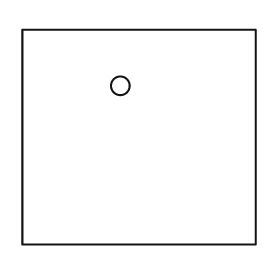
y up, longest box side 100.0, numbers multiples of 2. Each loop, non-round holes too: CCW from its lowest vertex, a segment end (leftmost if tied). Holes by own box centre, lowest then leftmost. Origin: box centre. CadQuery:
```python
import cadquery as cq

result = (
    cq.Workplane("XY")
    .moveTo(-50.0, -46.0)
    .lineTo(50.0, -46.0)
    .lineTo(50.0, 46.0)
    .lineTo(-50.0, 46.0)
    .close()
    .moveTo(-8.0, 22.0)
    .circle(4.0)
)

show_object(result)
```